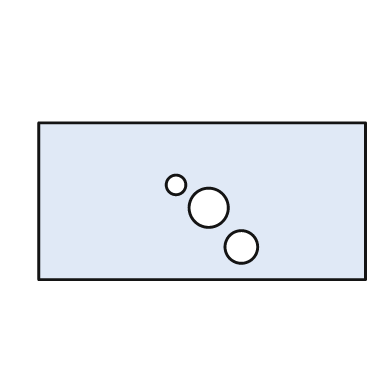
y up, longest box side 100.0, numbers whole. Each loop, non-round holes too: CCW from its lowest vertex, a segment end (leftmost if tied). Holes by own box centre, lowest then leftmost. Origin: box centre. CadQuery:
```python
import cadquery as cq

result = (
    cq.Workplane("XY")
    .moveTo(-50.0, -24.0)
    .lineTo(50.0, -24.0)
    .lineTo(50.0, 24.0)
    .lineTo(-50.0, 24.0)
    .close()
    .moveTo(12.0, -14.0)
    .circle(5.0)
    .moveTo(2.0, -2.0)
    .circle(6.0)
    .moveTo(-8.0, 5.0)
    .circle(3.0)
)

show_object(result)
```